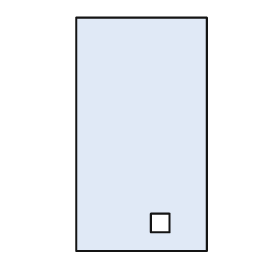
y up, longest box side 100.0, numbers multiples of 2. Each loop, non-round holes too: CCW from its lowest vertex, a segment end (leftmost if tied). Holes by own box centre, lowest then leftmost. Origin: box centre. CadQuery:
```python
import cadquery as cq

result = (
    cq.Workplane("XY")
    .moveTo(-28.0, -50.0)
    .lineTo(28.0, -50.0)
    .lineTo(28.0, 50.0)
    .lineTo(-28.0, 50.0)
    .close()
    .moveTo(4.0, -42.0)
    .lineTo(12.0, -42.0)
    .lineTo(12.0, -34.0)
    .lineTo(4.0, -34.0)
    .close()
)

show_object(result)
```